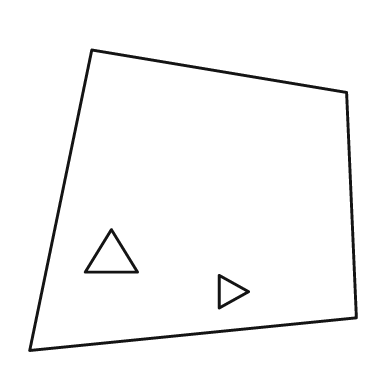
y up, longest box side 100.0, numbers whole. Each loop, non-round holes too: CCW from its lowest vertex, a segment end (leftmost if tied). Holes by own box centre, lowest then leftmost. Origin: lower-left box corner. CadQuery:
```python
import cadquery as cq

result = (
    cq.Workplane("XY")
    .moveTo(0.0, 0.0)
    .lineTo(100.0, 10.0)
    .lineTo(97.0, 79.0)
    .lineTo(19.0, 92.0)
    .close()
    .moveTo(58.0, 13.0)
    .lineTo(67.0, 18.0)
    .lineTo(58.0, 23.0)
    .close()
    .moveTo(17.0, 24.0)
    .lineTo(33.0, 24.0)
    .lineTo(25.0, 37.0)
    .close()
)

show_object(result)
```